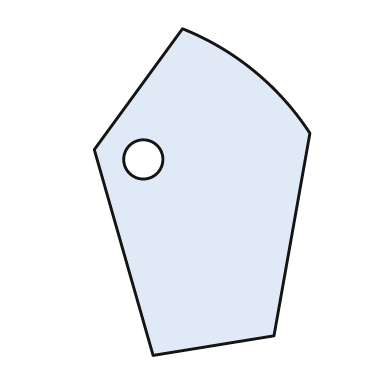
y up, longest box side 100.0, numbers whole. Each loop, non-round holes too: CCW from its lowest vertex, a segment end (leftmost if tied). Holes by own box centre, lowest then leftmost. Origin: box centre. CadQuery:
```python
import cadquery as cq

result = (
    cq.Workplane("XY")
    .moveTo(-15.0, -50.0)
    .lineTo(22.0, -44.0)
    .lineTo(33.0, 18.0)
    .threePointArc((16.0, 37.0), (-6.0, 50.0))
    .lineTo(-33.0, 13.0)
    .close()
    .moveTo(-18.0, 10.0)
    .circle(6.0)
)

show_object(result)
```